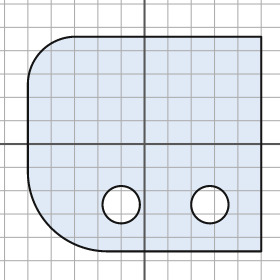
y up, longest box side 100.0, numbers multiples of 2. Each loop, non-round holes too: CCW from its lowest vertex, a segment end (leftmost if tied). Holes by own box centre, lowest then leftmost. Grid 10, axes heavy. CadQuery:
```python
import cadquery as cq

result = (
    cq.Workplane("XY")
    .moveTo(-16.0, -46.0)
    .lineTo(50.0, -46.0)
    .lineTo(50.0, 46.0)
    .lineTo(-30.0, 46.0)
    .threePointArc((-44.0, 40.0), (-50.0, 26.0))
    .lineTo(-50.0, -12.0)
    .threePointArc((-40.0, -36.0), (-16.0, -46.0))
    .close()
    .moveTo(-10.0, -26.0)
    .circle(8.0)
    .moveTo(28.0, -26.0)
    .circle(8.0)
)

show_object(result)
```